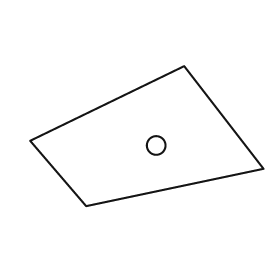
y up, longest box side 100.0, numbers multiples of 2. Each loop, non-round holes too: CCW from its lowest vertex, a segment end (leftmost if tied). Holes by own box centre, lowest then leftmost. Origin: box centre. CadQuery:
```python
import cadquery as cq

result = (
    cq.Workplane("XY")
    .moveTo(-26.0, -30.0)
    .lineTo(50.0, -14.0)
    .lineTo(16.0, 30.0)
    .lineTo(-50.0, -2.0)
    .close()
    .moveTo(4.0, -4.0)
    .circle(4.0)
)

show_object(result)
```